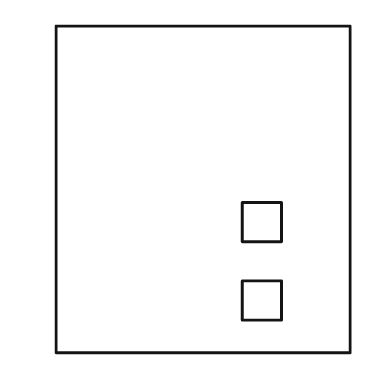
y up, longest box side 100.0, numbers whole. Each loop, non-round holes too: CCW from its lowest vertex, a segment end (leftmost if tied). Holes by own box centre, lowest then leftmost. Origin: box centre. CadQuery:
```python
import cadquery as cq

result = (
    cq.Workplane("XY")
    .moveTo(-45.0, -50.0)
    .lineTo(45.0, -50.0)
    .lineTo(45.0, 50.0)
    .lineTo(-45.0, 50.0)
    .close()
    .moveTo(12.0, -40.0)
    .lineTo(24.0, -40.0)
    .lineTo(24.0, -28.0)
    .lineTo(12.0, -28.0)
    .close()
    .moveTo(12.0, -16.0)
    .lineTo(24.0, -16.0)
    .lineTo(24.0, -4.0)
    .lineTo(12.0, -4.0)
    .close()
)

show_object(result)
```